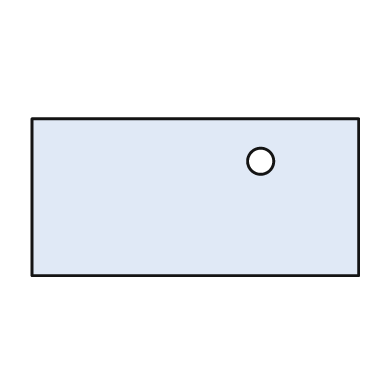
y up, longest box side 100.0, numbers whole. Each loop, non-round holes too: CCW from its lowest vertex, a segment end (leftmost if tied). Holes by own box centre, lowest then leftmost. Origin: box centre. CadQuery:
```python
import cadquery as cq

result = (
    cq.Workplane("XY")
    .moveTo(-50.0, -24.0)
    .lineTo(50.0, -24.0)
    .lineTo(50.0, 24.0)
    .lineTo(-50.0, 24.0)
    .close()
    .moveTo(20.0, 11.0)
    .circle(4.0)
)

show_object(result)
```